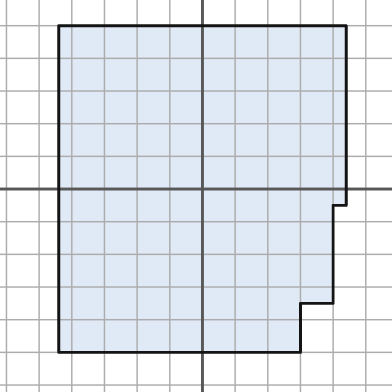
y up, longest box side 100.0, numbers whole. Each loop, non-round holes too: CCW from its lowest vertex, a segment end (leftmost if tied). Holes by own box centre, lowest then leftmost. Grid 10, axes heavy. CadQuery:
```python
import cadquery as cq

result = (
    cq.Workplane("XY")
    .moveTo(-44.0, -50.0)
    .lineTo(30.0, -50.0)
    .lineTo(30.0, -35.0)
    .lineTo(40.0, -35.0)
    .lineTo(40.0, -5.0)
    .lineTo(44.0, -5.0)
    .lineTo(44.0, 50.0)
    .lineTo(-44.0, 50.0)
    .close()
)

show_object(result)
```